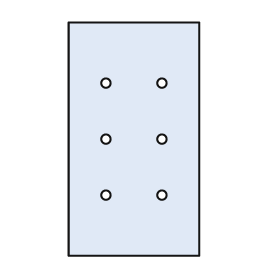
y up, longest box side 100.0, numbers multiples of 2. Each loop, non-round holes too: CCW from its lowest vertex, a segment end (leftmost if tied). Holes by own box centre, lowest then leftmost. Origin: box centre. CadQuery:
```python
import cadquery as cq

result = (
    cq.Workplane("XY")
    .moveTo(-28.0, -50.0)
    .lineTo(28.0, -50.0)
    .lineTo(28.0, 50.0)
    .lineTo(-28.0, 50.0)
    .close()
    .moveTo(-12.0, -24.0)
    .circle(2.0)
    .moveTo(12.0, -24.0)
    .circle(2.0)
    .moveTo(-12.0, 0.0)
    .circle(2.0)
    .moveTo(12.0, 0.0)
    .circle(2.0)
    .moveTo(-12.0, 24.0)
    .circle(2.0)
    .moveTo(12.0, 24.0)
    .circle(2.0)
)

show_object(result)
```